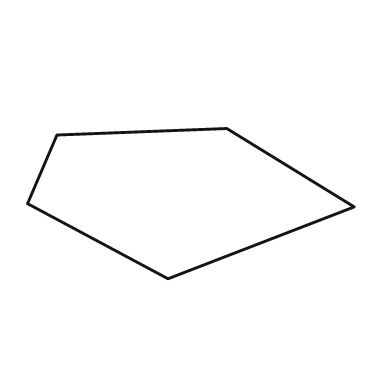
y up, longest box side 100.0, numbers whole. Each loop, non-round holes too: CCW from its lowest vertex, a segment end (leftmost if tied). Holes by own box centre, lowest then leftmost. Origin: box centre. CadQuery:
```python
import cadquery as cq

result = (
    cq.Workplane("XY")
    .moveTo(-7.0, -23.0)
    .lineTo(50.0, -1.0)
    .lineTo(11.0, 23.0)
    .lineTo(-41.0, 21.0)
    .lineTo(-50.0, 0.0)
    .close()
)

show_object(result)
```